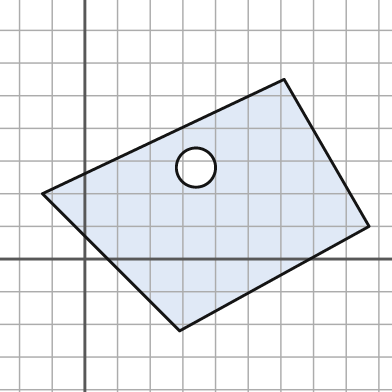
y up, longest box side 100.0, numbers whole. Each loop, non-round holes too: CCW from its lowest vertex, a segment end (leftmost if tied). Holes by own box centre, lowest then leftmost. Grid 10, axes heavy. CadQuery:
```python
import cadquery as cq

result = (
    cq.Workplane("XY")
    .moveTo(29.0, -22.0)
    .lineTo(87.0, 10.0)
    .lineTo(61.0, 55.0)
    .lineTo(-13.0, 20.0)
    .close()
    .moveTo(34.0, 28.0)
    .circle(6.0)
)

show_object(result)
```